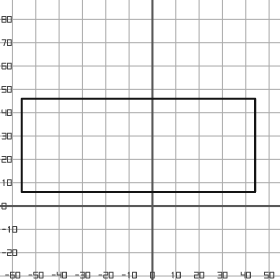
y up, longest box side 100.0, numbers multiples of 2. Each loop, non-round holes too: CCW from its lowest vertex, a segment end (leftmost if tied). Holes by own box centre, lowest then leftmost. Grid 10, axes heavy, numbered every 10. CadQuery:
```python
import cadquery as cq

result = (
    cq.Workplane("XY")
    .moveTo(-56.0, 6.0)
    .lineTo(44.0, 6.0)
    .lineTo(44.0, 46.0)
    .lineTo(-56.0, 46.0)
    .close()
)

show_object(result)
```